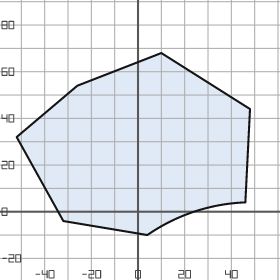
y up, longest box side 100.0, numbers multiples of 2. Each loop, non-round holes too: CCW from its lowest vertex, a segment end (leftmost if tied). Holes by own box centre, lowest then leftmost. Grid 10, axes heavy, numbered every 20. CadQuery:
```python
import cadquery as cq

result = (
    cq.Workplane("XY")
    .moveTo(4.0, -10.0)
    .threePointArc((24.0, 0.0), (46.0, 4.0))
    .lineTo(48.0, 44.0)
    .lineTo(10.0, 68.0)
    .lineTo(-26.0, 54.0)
    .lineTo(-52.0, 32.0)
    .lineTo(-32.0, -4.0)
    .close()
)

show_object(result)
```